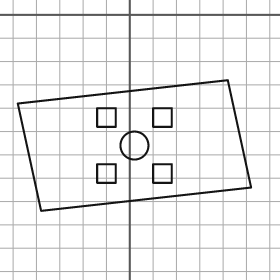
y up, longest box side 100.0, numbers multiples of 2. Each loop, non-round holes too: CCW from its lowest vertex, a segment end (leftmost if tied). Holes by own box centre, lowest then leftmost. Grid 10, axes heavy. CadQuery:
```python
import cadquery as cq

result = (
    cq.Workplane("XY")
    .moveTo(-38.0, -84.0)
    .lineTo(52.0, -74.0)
    .lineTo(42.0, -28.0)
    .lineTo(-48.0, -38.0)
    .close()
    .moveTo(-14.0, -72.0)
    .lineTo(-6.0, -72.0)
    .lineTo(-6.0, -64.0)
    .lineTo(-14.0, -64.0)
    .close()
    .moveTo(10.0, -72.0)
    .lineTo(18.0, -72.0)
    .lineTo(18.0, -64.0)
    .lineTo(10.0, -64.0)
    .close()
    .moveTo(2.0, -56.0)
    .circle(6.0)
    .moveTo(-14.0, -48.0)
    .lineTo(-6.0, -48.0)
    .lineTo(-6.0, -40.0)
    .lineTo(-14.0, -40.0)
    .close()
    .moveTo(10.0, -48.0)
    .lineTo(18.0, -48.0)
    .lineTo(18.0, -40.0)
    .lineTo(10.0, -40.0)
    .close()
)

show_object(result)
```